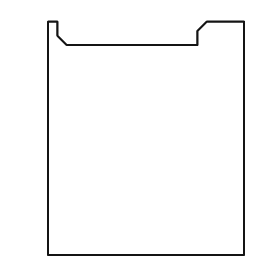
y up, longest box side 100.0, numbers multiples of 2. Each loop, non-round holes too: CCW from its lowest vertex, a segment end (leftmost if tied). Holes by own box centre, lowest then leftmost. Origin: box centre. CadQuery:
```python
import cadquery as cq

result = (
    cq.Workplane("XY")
    .moveTo(-42.0, -50.0)
    .lineTo(42.0, -50.0)
    .lineTo(42.0, 50.0)
    .lineTo(26.0, 50.0)
    .lineTo(22.0, 46.0)
    .lineTo(22.0, 40.0)
    .lineTo(-34.0, 40.0)
    .lineTo(-38.0, 44.0)
    .lineTo(-38.0, 50.0)
    .lineTo(-42.0, 50.0)
    .close()
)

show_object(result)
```